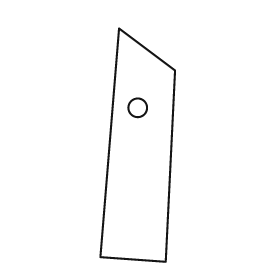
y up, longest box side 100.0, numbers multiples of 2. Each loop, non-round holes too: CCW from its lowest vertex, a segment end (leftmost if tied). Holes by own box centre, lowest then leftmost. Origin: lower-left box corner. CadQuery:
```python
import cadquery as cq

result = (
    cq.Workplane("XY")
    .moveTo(28.0, 0.0)
    .lineTo(32.0, 82.0)
    .lineTo(8.0, 100.0)
    .lineTo(0.0, 2.0)
    .close()
    .moveTo(16.0, 66.0)
    .circle(4.0)
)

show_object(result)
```